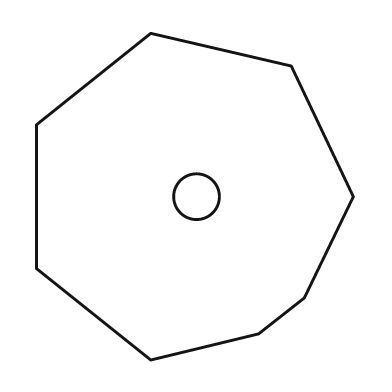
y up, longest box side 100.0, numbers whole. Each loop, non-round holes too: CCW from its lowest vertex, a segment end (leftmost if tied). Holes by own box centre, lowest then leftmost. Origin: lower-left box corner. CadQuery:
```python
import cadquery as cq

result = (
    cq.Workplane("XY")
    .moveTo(35.0, 0.0)
    .lineTo(68.0, 8.0)
    .lineTo(82.0, 19.0)
    .lineTo(97.0, 50.0)
    .lineTo(78.0, 90.0)
    .lineTo(35.0, 100.0)
    .lineTo(0.0, 72.0)
    .lineTo(0.0, 28.0)
    .close()
    .moveTo(49.0, 50.0)
    .circle(7.0)
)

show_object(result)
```